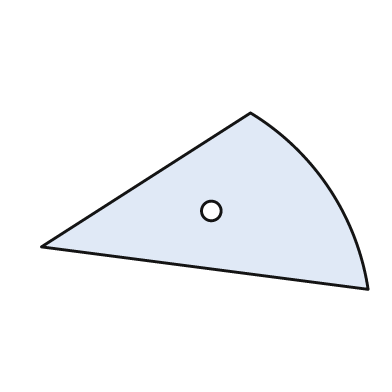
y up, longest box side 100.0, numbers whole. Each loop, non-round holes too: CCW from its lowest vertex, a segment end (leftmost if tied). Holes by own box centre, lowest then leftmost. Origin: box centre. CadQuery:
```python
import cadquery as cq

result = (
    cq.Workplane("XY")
    .moveTo(50.0, -27.0)
    .threePointArc((38.0, 4.0), (14.0, 27.0))
    .lineTo(-50.0, -14.0)
    .close()
    .moveTo(2.0, -3.0)
    .circle(3.0)
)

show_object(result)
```